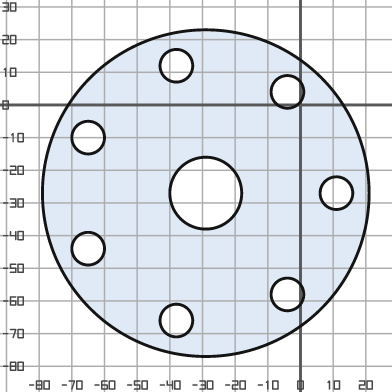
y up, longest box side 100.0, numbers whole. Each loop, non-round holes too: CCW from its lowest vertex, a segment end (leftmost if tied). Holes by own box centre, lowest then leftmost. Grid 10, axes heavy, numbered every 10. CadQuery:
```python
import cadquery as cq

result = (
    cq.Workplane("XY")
    .moveTo(-29.0, -27.0)
    .circle(50.0)
    .moveTo(-38.0, -66.0)
    .circle(5.0)
    .moveTo(-4.0, -58.0)
    .circle(5.0)
    .moveTo(-65.0, -44.0)
    .circle(5.0)
    .moveTo(-29.0, -27.0)
    .circle(11.0)
    .moveTo(11.0, -27.0)
    .circle(5.0)
    .moveTo(-65.0, -10.0)
    .circle(5.0)
    .moveTo(-4.0, 4.0)
    .circle(5.0)
    .moveTo(-38.0, 12.0)
    .circle(5.0)
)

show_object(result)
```